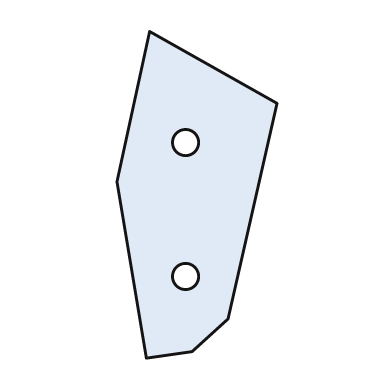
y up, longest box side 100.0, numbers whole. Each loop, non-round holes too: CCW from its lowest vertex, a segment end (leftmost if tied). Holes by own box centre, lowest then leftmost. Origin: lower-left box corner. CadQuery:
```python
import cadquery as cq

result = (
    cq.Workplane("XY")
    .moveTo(9.0, 0.0)
    .lineTo(23.0, 2.0)
    .lineTo(34.0, 12.0)
    .lineTo(49.0, 78.0)
    .lineTo(10.0, 100.0)
    .lineTo(0.0, 54.0)
    .close()
    .moveTo(21.0, 25.0)
    .circle(4.0)
    .moveTo(21.0, 66.0)
    .circle(4.0)
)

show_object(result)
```